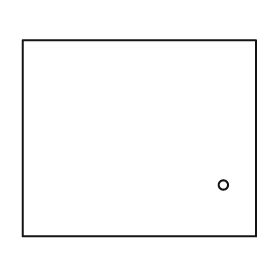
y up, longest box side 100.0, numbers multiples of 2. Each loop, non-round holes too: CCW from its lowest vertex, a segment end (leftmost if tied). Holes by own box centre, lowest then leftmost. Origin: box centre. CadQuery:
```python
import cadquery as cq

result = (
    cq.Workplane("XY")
    .moveTo(-50.0, -42.0)
    .lineTo(50.0, -42.0)
    .lineTo(50.0, 42.0)
    .lineTo(-50.0, 42.0)
    .close()
    .moveTo(36.0, -20.0)
    .circle(2.0)
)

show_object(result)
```